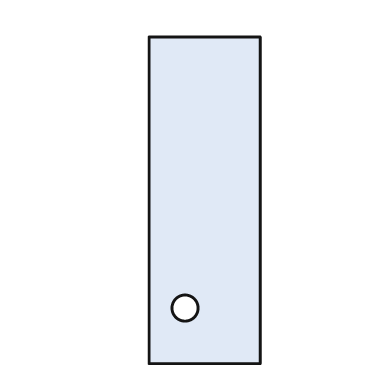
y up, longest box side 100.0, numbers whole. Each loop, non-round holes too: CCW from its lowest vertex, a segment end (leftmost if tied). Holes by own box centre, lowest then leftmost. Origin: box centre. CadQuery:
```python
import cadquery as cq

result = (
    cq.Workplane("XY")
    .moveTo(-17.0, -50.0)
    .lineTo(17.0, -50.0)
    .lineTo(17.0, 50.0)
    .lineTo(-17.0, 50.0)
    .close()
    .moveTo(-6.0, -33.0)
    .circle(4.0)
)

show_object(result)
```